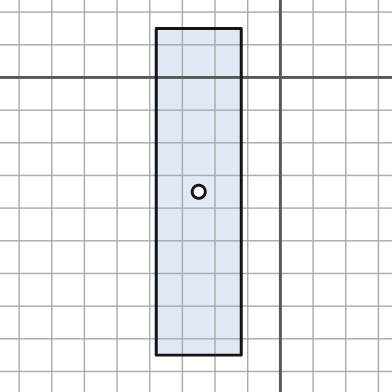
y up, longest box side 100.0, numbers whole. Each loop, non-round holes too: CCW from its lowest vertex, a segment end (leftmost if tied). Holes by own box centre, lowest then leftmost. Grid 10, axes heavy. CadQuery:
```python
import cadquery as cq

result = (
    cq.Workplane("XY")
    .moveTo(-38.0, -85.0)
    .lineTo(-12.0, -85.0)
    .lineTo(-12.0, 15.0)
    .lineTo(-38.0, 15.0)
    .close()
    .moveTo(-25.0, -35.0)
    .circle(2.0)
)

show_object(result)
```